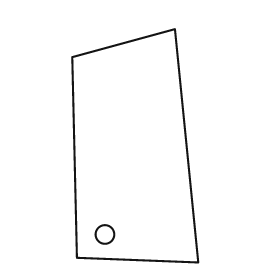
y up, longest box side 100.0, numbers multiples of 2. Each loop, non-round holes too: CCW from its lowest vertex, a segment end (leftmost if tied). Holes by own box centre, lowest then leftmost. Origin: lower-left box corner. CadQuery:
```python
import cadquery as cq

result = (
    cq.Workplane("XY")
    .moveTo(54.0, 0.0)
    .lineTo(44.0, 100.0)
    .lineTo(0.0, 88.0)
    .lineTo(2.0, 2.0)
    .close()
    .moveTo(14.0, 12.0)
    .circle(4.0)
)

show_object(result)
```